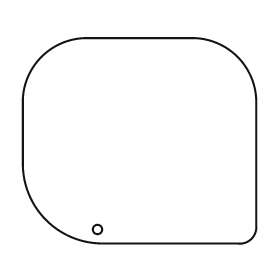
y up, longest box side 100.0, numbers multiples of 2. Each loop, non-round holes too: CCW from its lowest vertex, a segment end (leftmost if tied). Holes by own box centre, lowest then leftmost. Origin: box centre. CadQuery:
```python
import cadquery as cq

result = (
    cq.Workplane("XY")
    .moveTo(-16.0, -44.0)
    .lineTo(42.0, -44.0)
    .threePointArc((48.0, -42.0), (50.0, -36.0))
    .lineTo(50.0, 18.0)
    .threePointArc((42.0, 36.0), (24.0, 44.0))
    .lineTo(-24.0, 44.0)
    .threePointArc((-42.0, 36.0), (-50.0, 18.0))
    .lineTo(-50.0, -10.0)
    .threePointArc((-40.0, -34.0), (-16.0, -44.0))
    .close()
    .moveTo(-18.0, -38.0)
    .circle(2.0)
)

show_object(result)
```